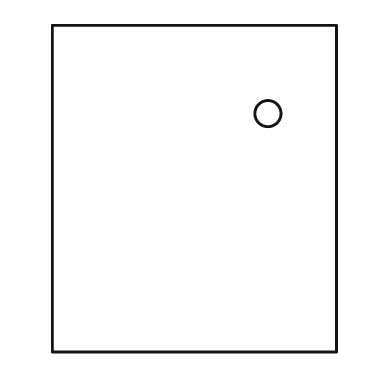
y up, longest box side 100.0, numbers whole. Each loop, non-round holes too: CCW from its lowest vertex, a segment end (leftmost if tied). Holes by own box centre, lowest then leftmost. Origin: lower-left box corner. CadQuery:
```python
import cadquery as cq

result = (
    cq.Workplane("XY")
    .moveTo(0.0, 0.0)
    .lineTo(87.0, 0.0)
    .lineTo(87.0, 100.0)
    .lineTo(0.0, 100.0)
    .close()
    .moveTo(66.0, 73.0)
    .circle(4.0)
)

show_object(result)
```